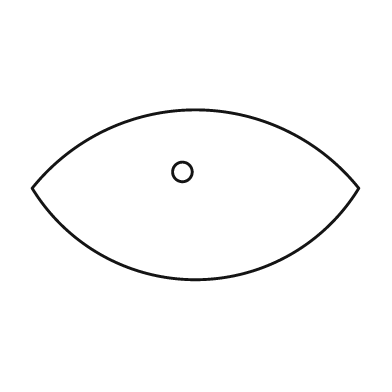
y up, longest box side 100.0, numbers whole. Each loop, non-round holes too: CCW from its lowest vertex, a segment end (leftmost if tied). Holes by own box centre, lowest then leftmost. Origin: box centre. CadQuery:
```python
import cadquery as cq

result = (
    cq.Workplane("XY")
    .moveTo(-50.0, 2.0)
    .threePointArc((0.0, -26.0), (50.0, 2.0))
    .threePointArc((0.0, 26.0), (-50.0, 2.0))
    .close()
    .moveTo(-4.0, 7.0)
    .circle(3.0)
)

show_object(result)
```